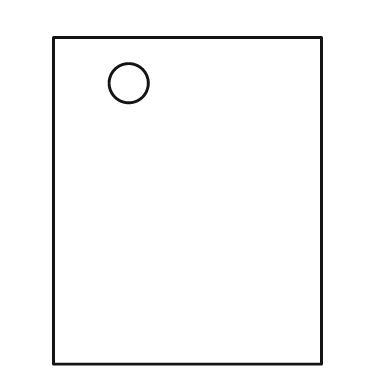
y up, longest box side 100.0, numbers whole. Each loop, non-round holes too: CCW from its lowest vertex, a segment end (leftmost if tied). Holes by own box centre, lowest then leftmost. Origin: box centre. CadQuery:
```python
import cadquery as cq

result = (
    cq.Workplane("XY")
    .moveTo(-41.0, -50.0)
    .lineTo(41.0, -50.0)
    .lineTo(41.0, 50.0)
    .lineTo(-41.0, 50.0)
    .close()
    .moveTo(-18.0, 36.0)
    .circle(6.0)
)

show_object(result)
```